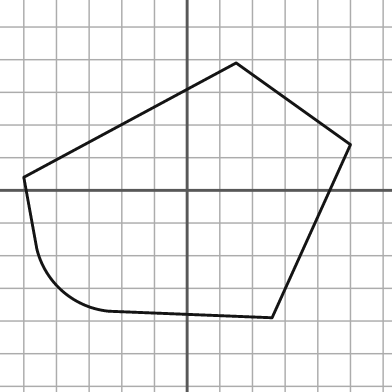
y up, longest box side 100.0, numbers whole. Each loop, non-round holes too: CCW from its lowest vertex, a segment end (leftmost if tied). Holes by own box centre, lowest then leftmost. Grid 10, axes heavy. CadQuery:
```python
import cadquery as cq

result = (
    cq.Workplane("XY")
    .moveTo(26.0, -39.0)
    .lineTo(50.0, 14.0)
    .lineTo(15.0, 39.0)
    .lineTo(-50.0, 4.0)
    .lineTo(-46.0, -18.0)
    .threePointArc((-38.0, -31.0), (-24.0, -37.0))
    .close()
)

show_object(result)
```